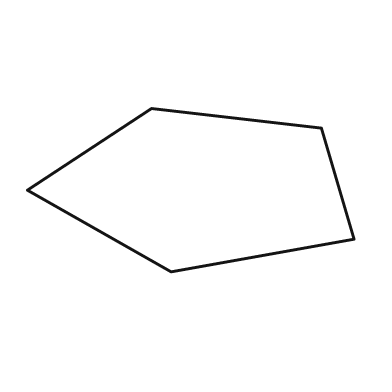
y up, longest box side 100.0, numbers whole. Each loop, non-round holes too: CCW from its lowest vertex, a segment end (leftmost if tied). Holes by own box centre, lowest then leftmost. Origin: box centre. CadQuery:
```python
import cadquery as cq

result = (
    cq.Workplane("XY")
    .moveTo(-6.0, -25.0)
    .lineTo(50.0, -15.0)
    .lineTo(40.0, 19.0)
    .lineTo(-12.0, 25.0)
    .lineTo(-50.0, 0.0)
    .close()
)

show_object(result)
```